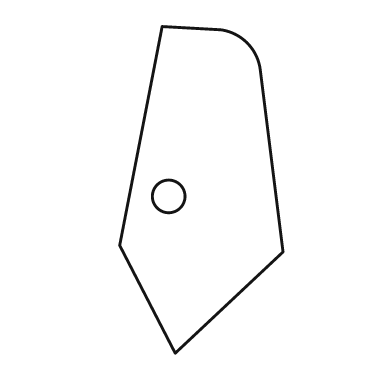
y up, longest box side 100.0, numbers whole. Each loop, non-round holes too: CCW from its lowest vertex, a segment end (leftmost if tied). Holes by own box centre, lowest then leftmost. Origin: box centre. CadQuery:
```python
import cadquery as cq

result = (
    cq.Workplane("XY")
    .moveTo(-8.0, -50.0)
    .lineTo(25.0, -19.0)
    .lineTo(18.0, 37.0)
    .threePointArc((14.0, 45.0), (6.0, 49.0))
    .lineTo(-12.0, 50.0)
    .lineTo(-25.0, -17.0)
    .close()
    .moveTo(-10.0, -2.0)
    .circle(5.0)
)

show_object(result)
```